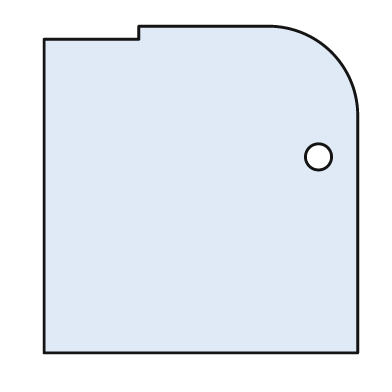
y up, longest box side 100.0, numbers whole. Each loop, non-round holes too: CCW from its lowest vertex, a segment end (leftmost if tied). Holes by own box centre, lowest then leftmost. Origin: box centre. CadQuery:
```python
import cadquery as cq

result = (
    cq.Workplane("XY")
    .moveTo(-48.0, -50.0)
    .lineTo(48.0, -50.0)
    .lineTo(48.0, 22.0)
    .threePointArc((40.0, 42.0), (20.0, 50.0))
    .lineTo(-19.0, 50.0)
    .lineTo(-19.0, 46.0)
    .lineTo(-48.0, 46.0)
    .close()
    .moveTo(36.0, 10.0)
    .circle(4.0)
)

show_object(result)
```